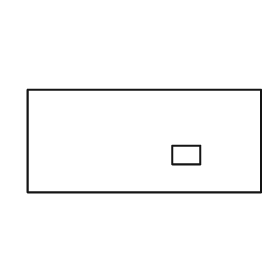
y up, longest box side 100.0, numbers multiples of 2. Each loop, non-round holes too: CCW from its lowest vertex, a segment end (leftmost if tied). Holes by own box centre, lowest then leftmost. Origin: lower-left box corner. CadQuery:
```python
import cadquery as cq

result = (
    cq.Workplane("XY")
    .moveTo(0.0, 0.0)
    .lineTo(100.0, 0.0)
    .lineTo(100.0, 44.0)
    .lineTo(0.0, 44.0)
    .close()
    .moveTo(62.0, 12.0)
    .lineTo(74.0, 12.0)
    .lineTo(74.0, 20.0)
    .lineTo(62.0, 20.0)
    .close()
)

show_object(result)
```